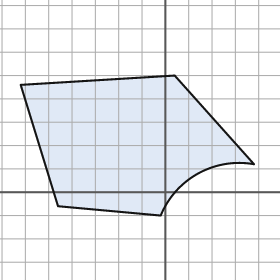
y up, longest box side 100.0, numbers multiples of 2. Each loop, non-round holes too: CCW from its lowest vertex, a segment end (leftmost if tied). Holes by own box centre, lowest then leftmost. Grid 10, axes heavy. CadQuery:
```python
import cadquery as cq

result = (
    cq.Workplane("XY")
    .moveTo(-2.0, -10.0)
    .threePointArc((14.0, 8.0), (38.0, 12.0))
    .lineTo(4.0, 50.0)
    .lineTo(-62.0, 46.0)
    .lineTo(-46.0, -6.0)
    .close()
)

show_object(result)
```